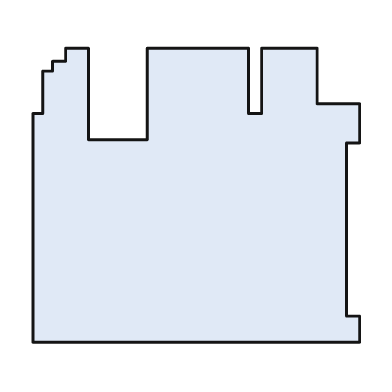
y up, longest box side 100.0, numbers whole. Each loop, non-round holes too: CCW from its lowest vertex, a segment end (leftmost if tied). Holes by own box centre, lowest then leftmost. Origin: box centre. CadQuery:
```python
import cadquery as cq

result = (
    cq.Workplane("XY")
    .moveTo(-50.0, -45.0)
    .lineTo(50.0, -45.0)
    .lineTo(50.0, -37.0)
    .lineTo(46.0, -37.0)
    .lineTo(46.0, 16.0)
    .lineTo(50.0, 16.0)
    .lineTo(50.0, 28.0)
    .lineTo(37.0, 28.0)
    .lineTo(37.0, 45.0)
    .lineTo(20.0, 45.0)
    .lineTo(20.0, 25.0)
    .lineTo(16.0, 25.0)
    .lineTo(16.0, 45.0)
    .lineTo(-15.0, 45.0)
    .lineTo(-15.0, 17.0)
    .lineTo(-33.0, 17.0)
    .lineTo(-33.0, 45.0)
    .lineTo(-40.0, 45.0)
    .lineTo(-40.0, 41.0)
    .lineTo(-44.0, 41.0)
    .lineTo(-44.0, 38.0)
    .lineTo(-47.0, 38.0)
    .lineTo(-47.0, 25.0)
    .lineTo(-50.0, 25.0)
    .close()
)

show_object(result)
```